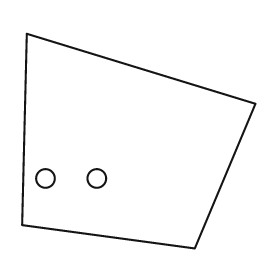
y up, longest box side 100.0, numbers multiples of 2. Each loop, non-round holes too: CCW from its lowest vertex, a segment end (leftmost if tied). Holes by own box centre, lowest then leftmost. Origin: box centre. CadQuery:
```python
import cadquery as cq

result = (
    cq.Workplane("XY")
    .moveTo(24.0, -46.0)
    .lineTo(50.0, 16.0)
    .lineTo(-48.0, 46.0)
    .lineTo(-50.0, -36.0)
    .close()
    .moveTo(-40.0, -16.0)
    .circle(4.0)
    .moveTo(-18.0, -16.0)
    .circle(4.0)
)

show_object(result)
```